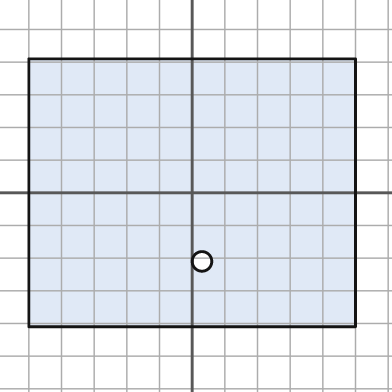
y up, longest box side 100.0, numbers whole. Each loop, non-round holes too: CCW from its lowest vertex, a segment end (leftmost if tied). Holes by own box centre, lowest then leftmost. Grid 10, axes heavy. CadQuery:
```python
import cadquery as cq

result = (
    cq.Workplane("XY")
    .moveTo(-50.0, -41.0)
    .lineTo(50.0, -41.0)
    .lineTo(50.0, 41.0)
    .lineTo(-50.0, 41.0)
    .close()
    .moveTo(3.0, -21.0)
    .circle(3.0)
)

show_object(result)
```